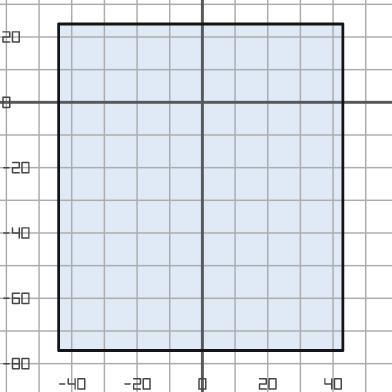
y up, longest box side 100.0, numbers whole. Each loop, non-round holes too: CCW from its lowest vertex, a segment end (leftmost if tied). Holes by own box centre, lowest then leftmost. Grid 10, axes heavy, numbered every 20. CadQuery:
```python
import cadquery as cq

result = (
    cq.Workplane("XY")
    .moveTo(-44.0, -76.0)
    .lineTo(43.0, -76.0)
    .lineTo(43.0, 24.0)
    .lineTo(-44.0, 24.0)
    .close()
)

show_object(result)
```